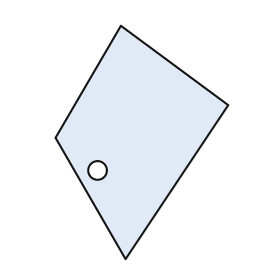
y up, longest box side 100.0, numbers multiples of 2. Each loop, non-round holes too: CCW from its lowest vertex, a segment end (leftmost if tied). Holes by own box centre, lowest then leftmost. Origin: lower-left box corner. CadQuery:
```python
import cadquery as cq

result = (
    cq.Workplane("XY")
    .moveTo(30.0, 0.0)
    .lineTo(74.0, 66.0)
    .lineTo(28.0, 100.0)
    .lineTo(0.0, 52.0)
    .close()
    .moveTo(18.0, 38.0)
    .circle(4.0)
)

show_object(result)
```